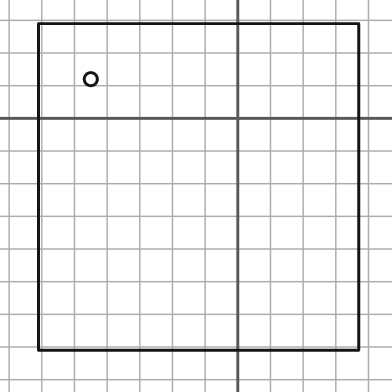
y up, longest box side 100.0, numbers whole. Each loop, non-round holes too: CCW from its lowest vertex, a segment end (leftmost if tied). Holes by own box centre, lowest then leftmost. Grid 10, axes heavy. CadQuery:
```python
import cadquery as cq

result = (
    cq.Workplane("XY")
    .moveTo(-61.0, -71.0)
    .lineTo(37.0, -71.0)
    .lineTo(37.0, 29.0)
    .lineTo(-61.0, 29.0)
    .close()
    .moveTo(-45.0, 12.0)
    .circle(2.0)
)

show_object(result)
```